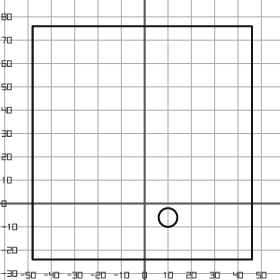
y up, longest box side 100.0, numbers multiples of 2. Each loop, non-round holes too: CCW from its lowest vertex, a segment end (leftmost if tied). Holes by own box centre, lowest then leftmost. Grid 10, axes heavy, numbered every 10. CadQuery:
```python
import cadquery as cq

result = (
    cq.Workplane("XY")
    .moveTo(-48.0, -24.0)
    .lineTo(46.0, -24.0)
    .lineTo(46.0, 76.0)
    .lineTo(-48.0, 76.0)
    .close()
    .moveTo(10.0, -6.0)
    .circle(4.0)
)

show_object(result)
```